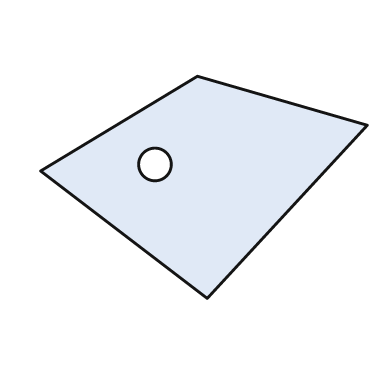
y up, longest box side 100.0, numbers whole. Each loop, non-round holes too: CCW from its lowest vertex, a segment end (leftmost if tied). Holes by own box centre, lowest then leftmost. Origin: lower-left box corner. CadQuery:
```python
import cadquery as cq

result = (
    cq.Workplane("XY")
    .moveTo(51.0, 0.0)
    .lineTo(100.0, 53.0)
    .lineTo(48.0, 68.0)
    .lineTo(0.0, 39.0)
    .close()
    .moveTo(35.0, 41.0)
    .circle(5.0)
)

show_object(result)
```